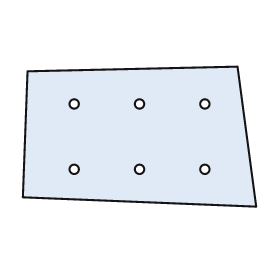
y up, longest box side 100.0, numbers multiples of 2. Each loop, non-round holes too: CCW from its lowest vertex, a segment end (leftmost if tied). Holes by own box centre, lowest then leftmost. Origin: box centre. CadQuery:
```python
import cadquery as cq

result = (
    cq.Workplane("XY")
    .moveTo(50.0, -30.0)
    .lineTo(42.0, 30.0)
    .lineTo(-48.0, 28.0)
    .lineTo(-50.0, -26.0)
    .close()
    .moveTo(-28.0, -14.0)
    .circle(2.0)
    .moveTo(0.0, -14.0)
    .circle(2.0)
    .moveTo(28.0, -14.0)
    .circle(2.0)
    .moveTo(-28.0, 14.0)
    .circle(2.0)
    .moveTo(0.0, 14.0)
    .circle(2.0)
    .moveTo(28.0, 14.0)
    .circle(2.0)
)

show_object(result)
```